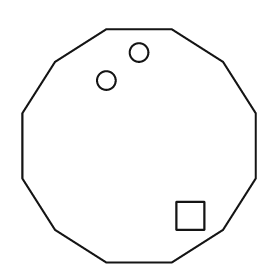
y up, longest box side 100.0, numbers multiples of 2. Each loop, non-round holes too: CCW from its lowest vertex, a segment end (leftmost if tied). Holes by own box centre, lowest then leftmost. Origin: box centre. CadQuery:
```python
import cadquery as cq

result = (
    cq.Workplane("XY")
    .moveTo(-14.0, -50.0)
    .lineTo(14.0, -50.0)
    .lineTo(36.0, -36.0)
    .lineTo(50.0, -14.0)
    .lineTo(50.0, 14.0)
    .lineTo(36.0, 36.0)
    .lineTo(14.0, 50.0)
    .lineTo(-14.0, 50.0)
    .lineTo(-36.0, 36.0)
    .lineTo(-50.0, 14.0)
    .lineTo(-50.0, -14.0)
    .lineTo(-36.0, -36.0)
    .close()
    .moveTo(16.0, -36.0)
    .lineTo(28.0, -36.0)
    .lineTo(28.0, -24.0)
    .lineTo(16.0, -24.0)
    .close()
    .moveTo(-14.0, 28.0)
    .circle(4.0)
    .moveTo(0.0, 40.0)
    .circle(4.0)
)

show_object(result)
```